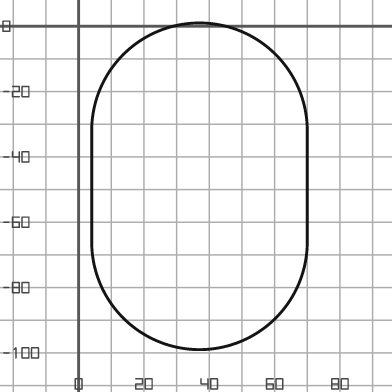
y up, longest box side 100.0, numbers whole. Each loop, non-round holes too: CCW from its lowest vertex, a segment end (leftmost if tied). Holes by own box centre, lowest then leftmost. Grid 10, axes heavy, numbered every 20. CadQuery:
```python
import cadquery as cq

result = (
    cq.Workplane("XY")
    .moveTo(4.0, -66.0)
    .threePointArc((37.0, -99.0), (70.0, -66.0))
    .lineTo(70.0, -32.0)
    .threePointArc((37.0, 1.0), (4.0, -32.0))
    .close()
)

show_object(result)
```